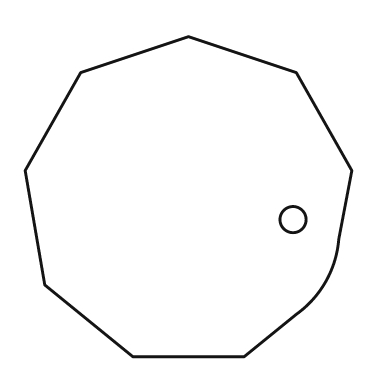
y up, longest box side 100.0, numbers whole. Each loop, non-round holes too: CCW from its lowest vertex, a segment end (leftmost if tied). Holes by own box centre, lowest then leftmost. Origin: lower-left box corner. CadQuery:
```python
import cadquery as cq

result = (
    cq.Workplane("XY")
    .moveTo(33.0, 0.0)
    .lineTo(67.0, 0.0)
    .lineTo(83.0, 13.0)
    .threePointArc((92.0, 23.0), (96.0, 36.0))
    .lineTo(100.0, 57.0)
    .lineTo(83.0, 87.0)
    .lineTo(50.0, 98.0)
    .lineTo(17.0, 87.0)
    .lineTo(0.0, 57.0)
    .lineTo(6.0, 22.0)
    .close()
    .moveTo(82.0, 42.0)
    .circle(4.0)
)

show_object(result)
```